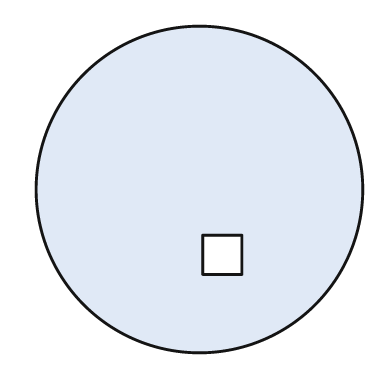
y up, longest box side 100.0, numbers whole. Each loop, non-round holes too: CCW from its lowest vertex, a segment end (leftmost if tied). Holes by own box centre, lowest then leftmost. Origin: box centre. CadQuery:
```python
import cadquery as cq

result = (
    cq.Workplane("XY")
    .moveTo(0.0, 0.0)
    .circle(50.0)
    .moveTo(1.0, -26.0)
    .lineTo(13.0, -26.0)
    .lineTo(13.0, -14.0)
    .lineTo(1.0, -14.0)
    .close()
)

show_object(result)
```